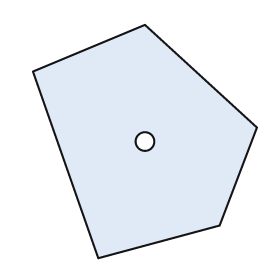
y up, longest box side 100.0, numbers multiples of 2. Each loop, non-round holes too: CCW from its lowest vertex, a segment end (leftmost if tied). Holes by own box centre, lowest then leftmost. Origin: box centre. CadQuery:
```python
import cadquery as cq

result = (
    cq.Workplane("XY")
    .moveTo(-20.0, -50.0)
    .lineTo(32.0, -36.0)
    .lineTo(48.0, 6.0)
    .lineTo(0.0, 50.0)
    .lineTo(-48.0, 30.0)
    .close()
    .moveTo(0.0, 0.0)
    .circle(4.0)
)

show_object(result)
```